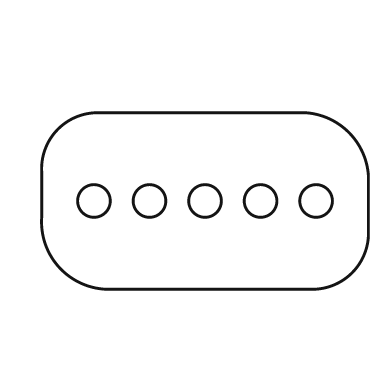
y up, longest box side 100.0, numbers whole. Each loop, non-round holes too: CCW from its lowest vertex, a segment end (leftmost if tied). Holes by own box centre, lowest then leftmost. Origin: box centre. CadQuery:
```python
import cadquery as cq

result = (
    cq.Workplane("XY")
    .moveTo(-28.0, -27.0)
    .lineTo(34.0, -27.0)
    .threePointArc((45.0, -22.0), (50.0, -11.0))
    .lineTo(50.0, 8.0)
    .threePointArc((44.0, 21.0), (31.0, 27.0))
    .lineTo(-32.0, 27.0)
    .threePointArc((-45.0, 22.0), (-50.0, 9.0))
    .lineTo(-50.0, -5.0)
    .threePointArc((-44.0, -21.0), (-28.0, -27.0))
    .close()
    .moveTo(-34.0, 0.0)
    .circle(5.0)
    .moveTo(-17.0, 0.0)
    .circle(5.0)
    .moveTo(0.0, 0.0)
    .circle(5.0)
    .moveTo(17.0, 0.0)
    .circle(5.0)
    .moveTo(34.0, 0.0)
    .circle(5.0)
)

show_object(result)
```